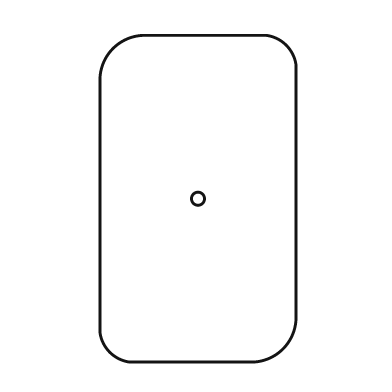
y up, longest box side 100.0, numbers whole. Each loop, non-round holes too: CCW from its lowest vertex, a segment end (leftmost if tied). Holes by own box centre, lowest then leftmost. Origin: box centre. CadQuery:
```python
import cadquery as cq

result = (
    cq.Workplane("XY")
    .moveTo(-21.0, -50.0)
    .lineTo(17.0, -50.0)
    .threePointArc((26.0, -46.0), (30.0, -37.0))
    .lineTo(30.0, 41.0)
    .threePointArc((27.0, 47.0), (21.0, 50.0))
    .lineTo(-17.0, 50.0)
    .threePointArc((-26.0, 46.0), (-30.0, 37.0))
    .lineTo(-30.0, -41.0)
    .threePointArc((-27.0, -47.0), (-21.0, -50.0))
    .close()
    .moveTo(0.0, 0.0)
    .circle(2.0)
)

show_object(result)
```